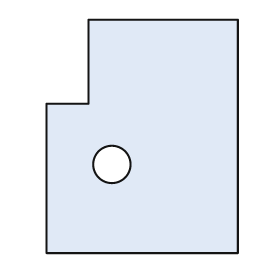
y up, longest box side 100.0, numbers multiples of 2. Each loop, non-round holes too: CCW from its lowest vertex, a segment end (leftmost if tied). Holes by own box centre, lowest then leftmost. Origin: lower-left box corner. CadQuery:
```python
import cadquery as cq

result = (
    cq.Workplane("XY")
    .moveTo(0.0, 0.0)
    .lineTo(82.0, 0.0)
    .lineTo(82.0, 100.0)
    .lineTo(18.0, 100.0)
    .lineTo(18.0, 64.0)
    .lineTo(0.0, 64.0)
    .close()
    .moveTo(28.0, 38.0)
    .circle(8.0)
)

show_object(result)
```